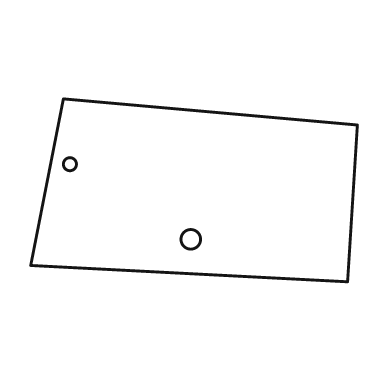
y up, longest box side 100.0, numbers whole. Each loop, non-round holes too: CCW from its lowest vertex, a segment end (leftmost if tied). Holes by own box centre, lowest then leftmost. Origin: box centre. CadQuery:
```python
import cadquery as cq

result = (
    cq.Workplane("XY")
    .moveTo(47.0, -28.0)
    .lineTo(50.0, 20.0)
    .lineTo(-40.0, 28.0)
    .lineTo(-50.0, -23.0)
    .close()
    .moveTo(-1.0, -15.0)
    .circle(3.0)
    .moveTo(-38.0, 8.0)
    .circle(2.0)
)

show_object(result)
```